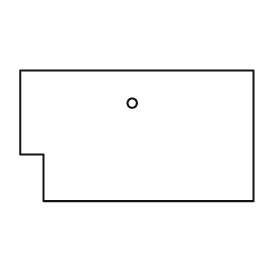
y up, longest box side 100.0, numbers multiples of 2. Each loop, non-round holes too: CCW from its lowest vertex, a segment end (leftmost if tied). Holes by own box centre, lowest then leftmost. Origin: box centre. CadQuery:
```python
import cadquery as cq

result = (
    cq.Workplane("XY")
    .moveTo(-40.0, -28.0)
    .lineTo(50.0, -28.0)
    .lineTo(50.0, 28.0)
    .lineTo(-50.0, 28.0)
    .lineTo(-50.0, -8.0)
    .lineTo(-40.0, -8.0)
    .close()
    .moveTo(-2.0, 14.0)
    .circle(2.0)
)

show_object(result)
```